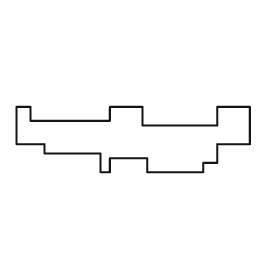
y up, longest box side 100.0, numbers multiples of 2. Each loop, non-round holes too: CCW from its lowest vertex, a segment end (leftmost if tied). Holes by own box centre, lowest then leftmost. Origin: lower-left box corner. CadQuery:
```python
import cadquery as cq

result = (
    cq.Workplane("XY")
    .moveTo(36.0, 0.0)
    .lineTo(40.0, 0.0)
    .lineTo(40.0, 6.0)
    .lineTo(56.0, 6.0)
    .lineTo(56.0, 0.0)
    .lineTo(80.0, 0.0)
    .lineTo(80.0, 4.0)
    .lineTo(86.0, 4.0)
    .lineTo(86.0, 12.0)
    .lineTo(100.0, 12.0)
    .lineTo(100.0, 28.0)
    .lineTo(86.0, 28.0)
    .lineTo(86.0, 20.0)
    .lineTo(54.0, 20.0)
    .lineTo(54.0, 28.0)
    .lineTo(40.0, 28.0)
    .lineTo(40.0, 22.0)
    .lineTo(6.0, 22.0)
    .lineTo(6.0, 28.0)
    .lineTo(0.0, 28.0)
    .lineTo(0.0, 12.0)
    .lineTo(12.0, 12.0)
    .lineTo(12.0, 8.0)
    .lineTo(36.0, 8.0)
    .close()
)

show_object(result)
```